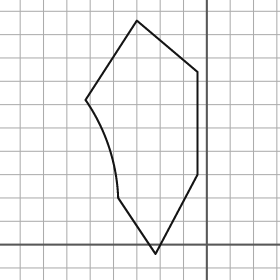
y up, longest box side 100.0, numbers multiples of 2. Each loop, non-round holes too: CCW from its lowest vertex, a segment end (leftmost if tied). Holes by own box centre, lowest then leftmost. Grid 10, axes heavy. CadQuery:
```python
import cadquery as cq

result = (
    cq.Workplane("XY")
    .moveTo(-22.0, -4.0)
    .lineTo(-4.0, 30.0)
    .lineTo(-4.0, 74.0)
    .lineTo(-30.0, 96.0)
    .lineTo(-52.0, 62.0)
    .threePointArc((-42.0, 42.0), (-38.0, 20.0))
    .close()
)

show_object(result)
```